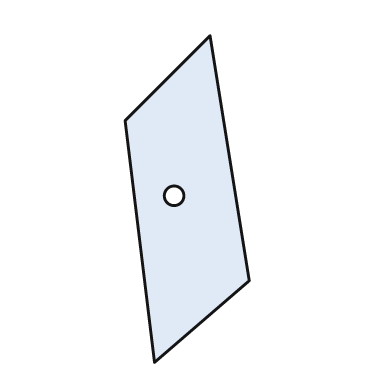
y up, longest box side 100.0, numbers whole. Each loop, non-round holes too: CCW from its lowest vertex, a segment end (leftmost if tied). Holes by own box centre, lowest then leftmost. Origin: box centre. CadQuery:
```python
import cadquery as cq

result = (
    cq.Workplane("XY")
    .moveTo(-10.0, -50.0)
    .lineTo(19.0, -25.0)
    .lineTo(7.0, 50.0)
    .lineTo(-19.0, 24.0)
    .close()
    .moveTo(-4.0, 1.0)
    .circle(3.0)
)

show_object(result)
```